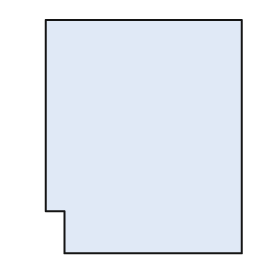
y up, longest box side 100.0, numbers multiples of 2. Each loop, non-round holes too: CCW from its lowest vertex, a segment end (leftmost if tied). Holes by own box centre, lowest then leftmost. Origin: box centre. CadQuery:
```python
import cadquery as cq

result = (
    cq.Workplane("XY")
    .moveTo(-34.0, -50.0)
    .lineTo(42.0, -50.0)
    .lineTo(42.0, 50.0)
    .lineTo(-42.0, 50.0)
    .lineTo(-42.0, -32.0)
    .lineTo(-34.0, -32.0)
    .close()
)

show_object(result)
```